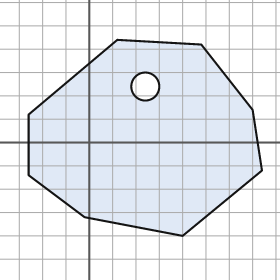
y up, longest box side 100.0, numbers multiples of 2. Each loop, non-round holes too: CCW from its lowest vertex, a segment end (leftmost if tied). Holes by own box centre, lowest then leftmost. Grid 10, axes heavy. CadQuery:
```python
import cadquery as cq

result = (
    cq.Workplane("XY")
    .moveTo(40.0, -40.0)
    .lineTo(74.0, -12.0)
    .lineTo(70.0, 14.0)
    .lineTo(48.0, 42.0)
    .lineTo(12.0, 44.0)
    .lineTo(-26.0, 12.0)
    .lineTo(-26.0, -14.0)
    .lineTo(-2.0, -32.0)
    .close()
    .moveTo(24.0, 24.0)
    .circle(6.0)
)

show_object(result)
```